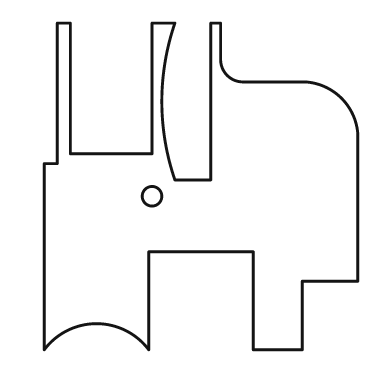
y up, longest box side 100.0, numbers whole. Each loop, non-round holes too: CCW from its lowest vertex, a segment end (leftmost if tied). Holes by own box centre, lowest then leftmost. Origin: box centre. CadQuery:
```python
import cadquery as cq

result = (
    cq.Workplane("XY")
    .moveTo(-48.0, -50.0)
    .threePointArc((-32.0, -42.0), (-16.0, -50.0))
    .lineTo(-16.0, -20.0)
    .lineTo(16.0, -20.0)
    .lineTo(16.0, -50.0)
    .lineTo(31.0, -50.0)
    .lineTo(31.0, -29.0)
    .lineTo(48.0, -29.0)
    .lineTo(48.0, 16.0)
    .threePointArc((43.0, 27.0), (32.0, 32.0))
    .lineTo(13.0, 32.0)
    .threePointArc((8.0, 34.0), (6.0, 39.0))
    .lineTo(6.0, 50.0)
    .lineTo(3.0, 50.0)
    .lineTo(3.0, 2.0)
    .lineTo(-8.0, 2.0)
    .threePointArc((-12.0, 26.0), (-8.0, 50.0))
    .lineTo(-15.0, 50.0)
    .lineTo(-15.0, 10.0)
    .lineTo(-40.0, 10.0)
    .lineTo(-40.0, 50.0)
    .lineTo(-44.0, 50.0)
    .lineTo(-44.0, 7.0)
    .lineTo(-48.0, 7.0)
    .close()
    .moveTo(-15.0, -3.0)
    .circle(3.0)
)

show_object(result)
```